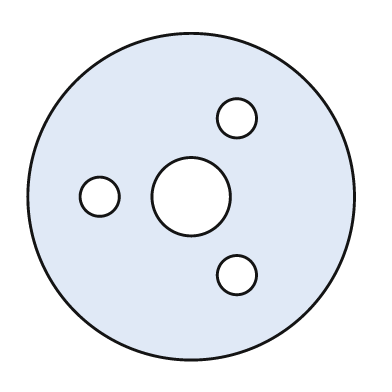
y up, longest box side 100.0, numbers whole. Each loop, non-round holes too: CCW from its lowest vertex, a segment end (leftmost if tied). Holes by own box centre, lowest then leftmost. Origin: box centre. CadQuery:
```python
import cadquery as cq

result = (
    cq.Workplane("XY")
    .moveTo(0.0, 0.0)
    .circle(50.0)
    .moveTo(14.0, -24.0)
    .circle(6.0)
    .moveTo(-28.0, 0.0)
    .circle(6.0)
    .moveTo(0.0, 0.0)
    .circle(12.0)
    .moveTo(14.0, 24.0)
    .circle(6.0)
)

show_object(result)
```